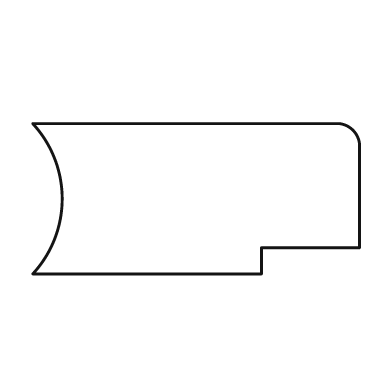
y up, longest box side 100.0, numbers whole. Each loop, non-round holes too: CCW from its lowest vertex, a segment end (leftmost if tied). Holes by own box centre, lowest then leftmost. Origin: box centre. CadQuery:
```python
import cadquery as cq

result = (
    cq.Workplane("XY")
    .moveTo(-50.0, -23.0)
    .lineTo(20.0, -23.0)
    .lineTo(20.0, -15.0)
    .lineTo(50.0, -15.0)
    .lineTo(50.0, 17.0)
    .threePointArc((48.0, 21.0), (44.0, 23.0))
    .lineTo(-50.0, 23.0)
    .threePointArc((-41.0, 0.0), (-50.0, -23.0))
    .close()
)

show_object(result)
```